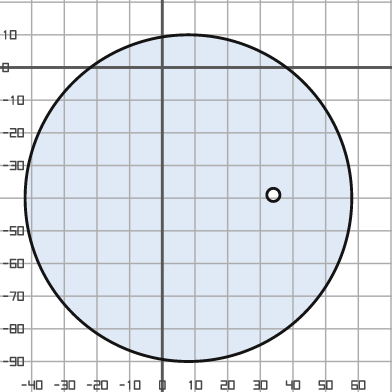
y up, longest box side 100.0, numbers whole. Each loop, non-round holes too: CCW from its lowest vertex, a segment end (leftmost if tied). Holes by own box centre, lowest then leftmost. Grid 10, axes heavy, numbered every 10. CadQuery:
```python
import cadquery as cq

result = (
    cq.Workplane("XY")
    .moveTo(8.0, -40.0)
    .circle(50.0)
    .moveTo(34.0, -39.0)
    .circle(2.0)
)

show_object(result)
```